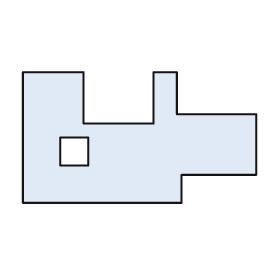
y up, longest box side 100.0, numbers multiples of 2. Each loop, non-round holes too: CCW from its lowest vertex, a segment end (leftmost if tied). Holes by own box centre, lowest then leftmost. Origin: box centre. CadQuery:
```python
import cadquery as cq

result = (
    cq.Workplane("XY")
    .moveTo(-50.0, -28.0)
    .lineTo(18.0, -28.0)
    .lineTo(18.0, -16.0)
    .lineTo(50.0, -16.0)
    .lineTo(50.0, 10.0)
    .lineTo(16.0, 10.0)
    .lineTo(16.0, 28.0)
    .lineTo(6.0, 28.0)
    .lineTo(6.0, 6.0)
    .lineTo(-24.0, 6.0)
    .lineTo(-24.0, 28.0)
    .lineTo(-50.0, 28.0)
    .close()
    .moveTo(-34.0, -12.0)
    .lineTo(-22.0, -12.0)
    .lineTo(-22.0, 0.0)
    .lineTo(-34.0, 0.0)
    .close()
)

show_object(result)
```